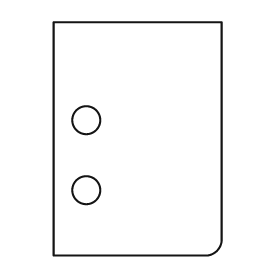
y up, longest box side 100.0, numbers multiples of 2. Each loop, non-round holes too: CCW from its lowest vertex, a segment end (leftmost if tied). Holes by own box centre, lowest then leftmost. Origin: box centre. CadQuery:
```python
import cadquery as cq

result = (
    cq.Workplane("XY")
    .moveTo(-36.0, -50.0)
    .lineTo(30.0, -50.0)
    .threePointArc((34.0, -48.0), (36.0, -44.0))
    .lineTo(36.0, 50.0)
    .lineTo(-36.0, 50.0)
    .close()
    .moveTo(-22.0, -22.0)
    .circle(6.0)
    .moveTo(-22.0, 8.0)
    .circle(6.0)
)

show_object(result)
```